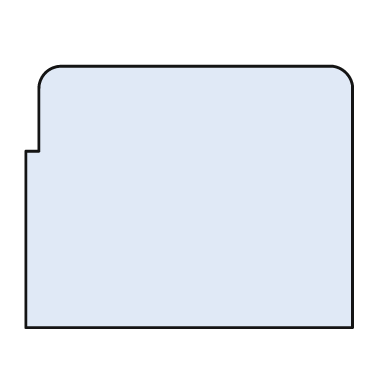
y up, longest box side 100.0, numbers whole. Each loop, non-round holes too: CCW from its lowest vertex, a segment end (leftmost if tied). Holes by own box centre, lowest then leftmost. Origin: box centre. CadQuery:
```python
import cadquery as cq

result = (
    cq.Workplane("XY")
    .moveTo(-50.0, -40.0)
    .lineTo(50.0, -40.0)
    .lineTo(50.0, 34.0)
    .threePointArc((48.0, 38.0), (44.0, 40.0))
    .lineTo(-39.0, 40.0)
    .threePointArc((-44.0, 38.0), (-46.0, 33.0))
    .lineTo(-46.0, 14.0)
    .lineTo(-50.0, 14.0)
    .close()
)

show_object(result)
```